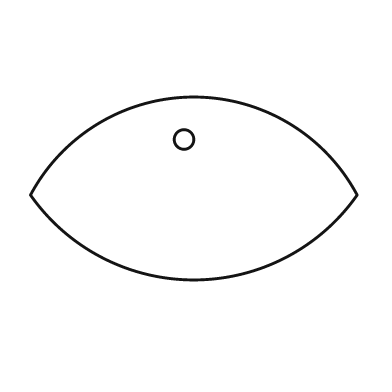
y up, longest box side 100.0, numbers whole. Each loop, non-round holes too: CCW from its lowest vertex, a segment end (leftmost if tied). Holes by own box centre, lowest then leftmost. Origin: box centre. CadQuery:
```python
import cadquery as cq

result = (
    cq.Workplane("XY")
    .moveTo(-50.0, -2.0)
    .threePointArc((0.0, -28.0), (50.0, -2.0))
    .threePointArc((0.0, 28.0), (-50.0, -2.0))
    .close()
    .moveTo(-3.0, 15.0)
    .circle(3.0)
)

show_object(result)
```